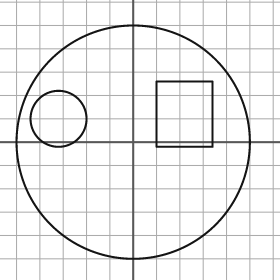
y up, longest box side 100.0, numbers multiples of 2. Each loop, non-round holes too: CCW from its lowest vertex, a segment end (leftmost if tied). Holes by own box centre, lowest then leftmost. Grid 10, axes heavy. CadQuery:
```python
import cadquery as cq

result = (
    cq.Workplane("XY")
    .moveTo(0.0, 0.0)
    .circle(50.0)
    .moveTo(-32.0, 10.0)
    .circle(12.0)
    .moveTo(10.0, -2.0)
    .lineTo(34.0, -2.0)
    .lineTo(34.0, 26.0)
    .lineTo(10.0, 26.0)
    .close()
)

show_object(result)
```